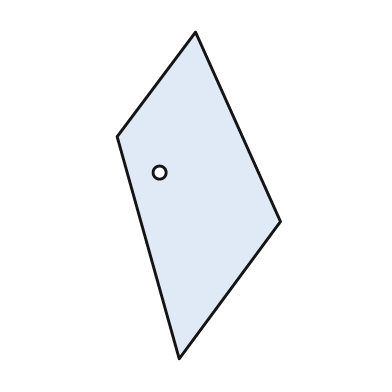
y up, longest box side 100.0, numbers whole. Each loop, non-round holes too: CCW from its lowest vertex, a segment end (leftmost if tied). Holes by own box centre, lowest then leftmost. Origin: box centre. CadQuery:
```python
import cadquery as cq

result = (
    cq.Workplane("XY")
    .moveTo(-6.0, -50.0)
    .lineTo(25.0, -8.0)
    .lineTo(-1.0, 50.0)
    .lineTo(-25.0, 18.0)
    .close()
    .moveTo(-12.0, 7.0)
    .circle(2.0)
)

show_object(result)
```